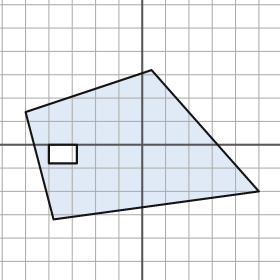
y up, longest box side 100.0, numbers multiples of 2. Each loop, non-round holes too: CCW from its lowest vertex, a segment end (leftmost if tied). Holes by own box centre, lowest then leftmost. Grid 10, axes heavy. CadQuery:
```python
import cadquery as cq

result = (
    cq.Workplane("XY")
    .moveTo(-38.0, -32.0)
    .lineTo(50.0, -20.0)
    .lineTo(4.0, 32.0)
    .lineTo(-50.0, 14.0)
    .close()
    .moveTo(-40.0, -8.0)
    .lineTo(-28.0, -8.0)
    .lineTo(-28.0, 0.0)
    .lineTo(-40.0, 0.0)
    .close()
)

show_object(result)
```